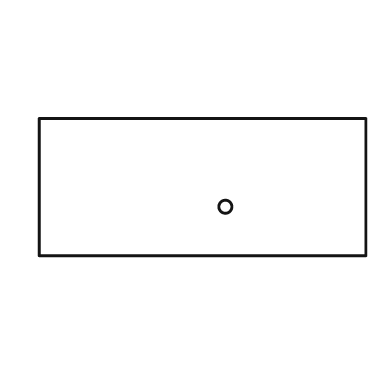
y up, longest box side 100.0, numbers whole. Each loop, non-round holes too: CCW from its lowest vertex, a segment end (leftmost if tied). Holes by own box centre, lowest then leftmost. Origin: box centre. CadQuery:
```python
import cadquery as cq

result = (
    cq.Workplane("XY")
    .moveTo(-50.0, -21.0)
    .lineTo(50.0, -21.0)
    .lineTo(50.0, 21.0)
    .lineTo(-50.0, 21.0)
    .close()
    .moveTo(7.0, -6.0)
    .circle(2.0)
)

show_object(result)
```